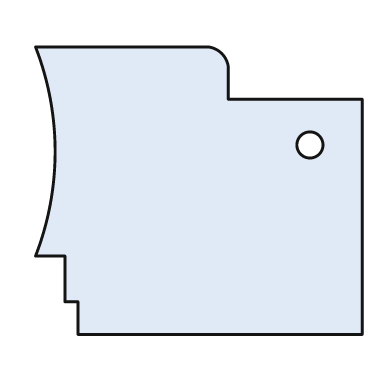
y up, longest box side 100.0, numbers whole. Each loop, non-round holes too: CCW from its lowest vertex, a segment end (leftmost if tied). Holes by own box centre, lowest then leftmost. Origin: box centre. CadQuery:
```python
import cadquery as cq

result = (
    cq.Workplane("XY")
    .moveTo(-37.0, -44.0)
    .lineTo(50.0, -44.0)
    .lineTo(50.0, 28.0)
    .lineTo(9.0, 28.0)
    .lineTo(9.0, 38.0)
    .threePointArc((7.0, 42.0), (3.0, 44.0))
    .lineTo(-50.0, 44.0)
    .threePointArc((-44.0, 12.0), (-50.0, -20.0))
    .lineTo(-41.0, -20.0)
    .lineTo(-41.0, -34.0)
    .lineTo(-37.0, -34.0)
    .close()
    .moveTo(34.0, 14.0)
    .circle(4.0)
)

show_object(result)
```